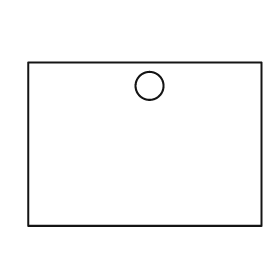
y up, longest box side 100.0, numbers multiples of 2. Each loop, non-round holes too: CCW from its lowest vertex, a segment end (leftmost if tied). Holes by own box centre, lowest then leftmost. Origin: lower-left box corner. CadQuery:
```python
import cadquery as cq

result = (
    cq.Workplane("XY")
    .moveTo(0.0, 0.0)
    .lineTo(100.0, 0.0)
    .lineTo(100.0, 70.0)
    .lineTo(0.0, 70.0)
    .close()
    .moveTo(52.0, 60.0)
    .circle(6.0)
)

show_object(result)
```